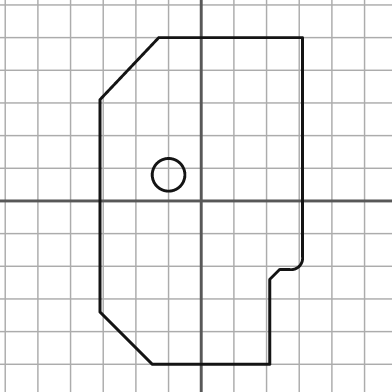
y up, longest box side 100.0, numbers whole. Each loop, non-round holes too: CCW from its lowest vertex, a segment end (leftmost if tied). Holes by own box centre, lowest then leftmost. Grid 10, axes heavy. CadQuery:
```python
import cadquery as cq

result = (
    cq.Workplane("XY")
    .moveTo(-15.0, -50.0)
    .lineTo(21.0, -50.0)
    .lineTo(21.0, -24.0)
    .lineTo(24.0, -21.0)
    .lineTo(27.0, -21.0)
    .threePointArc((30.0, -20.0), (31.0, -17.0))
    .lineTo(31.0, 50.0)
    .lineTo(-13.0, 50.0)
    .lineTo(-31.0, 31.0)
    .lineTo(-31.0, -34.0)
    .close()
    .moveTo(-10.0, 8.0)
    .circle(5.0)
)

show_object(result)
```